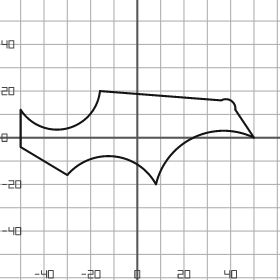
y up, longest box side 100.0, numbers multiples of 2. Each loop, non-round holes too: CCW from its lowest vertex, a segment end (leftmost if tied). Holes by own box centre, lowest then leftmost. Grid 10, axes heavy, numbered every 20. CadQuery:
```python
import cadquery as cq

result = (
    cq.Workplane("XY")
    .moveTo(8.0, -20.0)
    .threePointArc((24.0, 0.0), (50.0, 0.0))
    .lineTo(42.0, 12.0)
    .threePointArc((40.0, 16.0), (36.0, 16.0))
    .lineTo(-16.0, 20.0)
    .threePointArc((-30.0, 4.0), (-50.0, 12.0))
    .lineTo(-50.0, -4.0)
    .lineTo(-30.0, -16.0)
    .threePointArc((-10.0, -8.0), (8.0, -20.0))
    .close()
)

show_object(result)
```